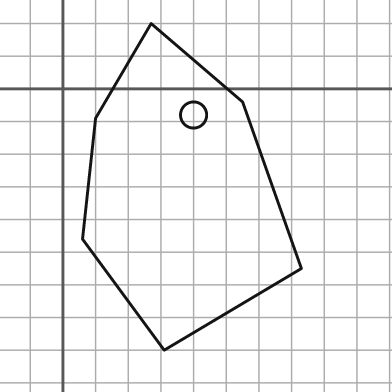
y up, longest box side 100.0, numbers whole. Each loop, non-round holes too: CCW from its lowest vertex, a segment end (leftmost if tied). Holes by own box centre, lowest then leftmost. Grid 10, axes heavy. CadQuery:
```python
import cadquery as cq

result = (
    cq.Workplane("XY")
    .moveTo(31.0, -80.0)
    .lineTo(73.0, -55.0)
    .lineTo(55.0, -4.0)
    .lineTo(27.0, 20.0)
    .lineTo(10.0, -9.0)
    .lineTo(6.0, -46.0)
    .close()
    .moveTo(40.0, -8.0)
    .circle(4.0)
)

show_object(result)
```